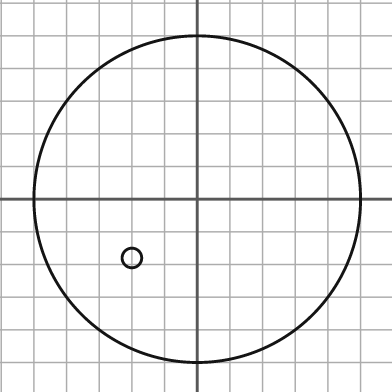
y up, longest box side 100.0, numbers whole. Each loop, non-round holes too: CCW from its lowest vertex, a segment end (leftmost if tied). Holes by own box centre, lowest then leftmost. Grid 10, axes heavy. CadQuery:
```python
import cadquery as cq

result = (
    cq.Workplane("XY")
    .moveTo(0.0, 0.0)
    .circle(50.0)
    .moveTo(-20.0, -18.0)
    .circle(3.0)
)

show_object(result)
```